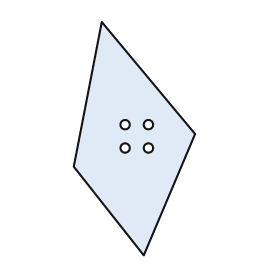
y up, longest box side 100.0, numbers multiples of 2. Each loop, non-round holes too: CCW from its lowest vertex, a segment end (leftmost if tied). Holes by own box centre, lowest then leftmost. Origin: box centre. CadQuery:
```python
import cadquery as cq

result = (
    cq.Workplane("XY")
    .moveTo(4.0, -50.0)
    .lineTo(26.0, 2.0)
    .lineTo(-14.0, 50.0)
    .lineTo(-26.0, -12.0)
    .close()
    .moveTo(-4.0, -4.0)
    .circle(2.0)
    .moveTo(6.0, -4.0)
    .circle(2.0)
    .moveTo(-4.0, 6.0)
    .circle(2.0)
    .moveTo(6.0, 6.0)
    .circle(2.0)
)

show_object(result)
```